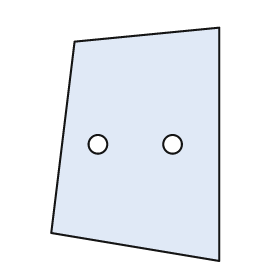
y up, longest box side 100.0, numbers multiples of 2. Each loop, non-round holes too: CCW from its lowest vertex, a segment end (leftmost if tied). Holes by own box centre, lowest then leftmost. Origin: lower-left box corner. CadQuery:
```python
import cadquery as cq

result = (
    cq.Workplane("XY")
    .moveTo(72.0, 0.0)
    .lineTo(72.0, 100.0)
    .lineTo(10.0, 94.0)
    .lineTo(0.0, 12.0)
    .close()
    .moveTo(20.0, 50.0)
    .circle(4.0)
    .moveTo(52.0, 50.0)
    .circle(4.0)
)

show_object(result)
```